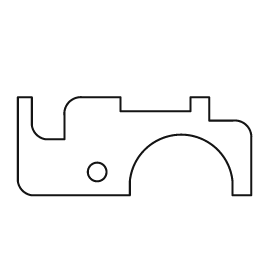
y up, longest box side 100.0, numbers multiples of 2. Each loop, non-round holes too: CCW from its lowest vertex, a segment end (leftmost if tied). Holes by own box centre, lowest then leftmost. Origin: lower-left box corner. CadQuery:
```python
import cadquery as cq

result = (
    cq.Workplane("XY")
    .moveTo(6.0, 0.0)
    .lineTo(48.0, 0.0)
    .lineTo(48.0, 6.0)
    .threePointArc((70.0, 26.0), (92.0, 6.0))
    .lineTo(92.0, 0.0)
    .lineTo(100.0, 0.0)
    .lineTo(100.0, 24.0)
    .threePointArc((98.0, 30.0), (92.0, 32.0))
    .lineTo(82.0, 32.0)
    .lineTo(82.0, 42.0)
    .lineTo(74.0, 42.0)
    .lineTo(74.0, 36.0)
    .lineTo(44.0, 36.0)
    .lineTo(44.0, 42.0)
    .lineTo(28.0, 42.0)
    .threePointArc((22.0, 40.0), (20.0, 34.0))
    .lineTo(20.0, 24.0)
    .lineTo(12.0, 24.0)
    .threePointArc((8.0, 26.0), (6.0, 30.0))
    .lineTo(6.0, 42.0)
    .lineTo(0.0, 42.0)
    .lineTo(0.0, 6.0)
    .threePointArc((2.0, 2.0), (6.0, 0.0))
    .close()
    .moveTo(34.0, 10.0)
    .circle(4.0)
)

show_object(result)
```